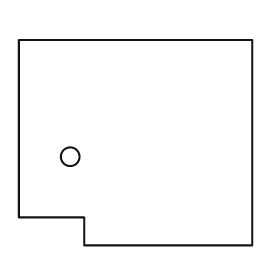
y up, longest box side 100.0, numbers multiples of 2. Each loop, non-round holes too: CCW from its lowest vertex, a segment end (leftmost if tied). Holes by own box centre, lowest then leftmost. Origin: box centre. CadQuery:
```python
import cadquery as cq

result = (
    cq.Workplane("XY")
    .moveTo(-22.0, -44.0)
    .lineTo(50.0, -44.0)
    .lineTo(50.0, 44.0)
    .lineTo(-50.0, 44.0)
    .lineTo(-50.0, -32.0)
    .lineTo(-22.0, -32.0)
    .close()
    .moveTo(-28.0, -6.0)
    .circle(4.0)
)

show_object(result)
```